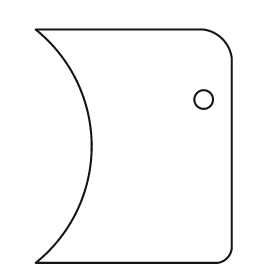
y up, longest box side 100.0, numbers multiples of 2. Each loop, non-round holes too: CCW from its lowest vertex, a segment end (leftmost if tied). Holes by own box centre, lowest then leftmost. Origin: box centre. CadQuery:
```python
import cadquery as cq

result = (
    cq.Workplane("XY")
    .moveTo(-42.0, -50.0)
    .lineTo(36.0, -50.0)
    .threePointArc((40.0, -48.0), (42.0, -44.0))
    .lineTo(42.0, 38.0)
    .threePointArc((38.0, 46.0), (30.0, 50.0))
    .lineTo(-42.0, 50.0)
    .threePointArc((-18.0, 0.0), (-42.0, -50.0))
    .close()
    .moveTo(30.0, 20.0)
    .circle(4.0)
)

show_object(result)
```